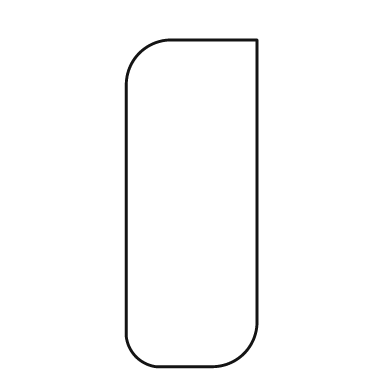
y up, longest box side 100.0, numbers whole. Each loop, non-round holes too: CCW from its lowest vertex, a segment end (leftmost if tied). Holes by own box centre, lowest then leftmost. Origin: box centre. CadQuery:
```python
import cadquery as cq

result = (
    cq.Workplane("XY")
    .moveTo(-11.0, -50.0)
    .lineTo(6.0, -50.0)
    .threePointArc((16.0, -46.0), (20.0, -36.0))
    .lineTo(20.0, 50.0)
    .lineTo(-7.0, 50.0)
    .threePointArc((-16.0, 46.0), (-20.0, 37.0))
    .lineTo(-20.0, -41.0)
    .threePointArc((-17.0, -47.0), (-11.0, -50.0))
    .close()
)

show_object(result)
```